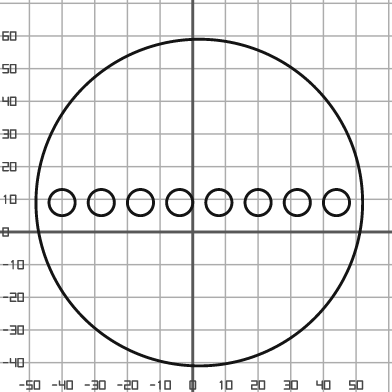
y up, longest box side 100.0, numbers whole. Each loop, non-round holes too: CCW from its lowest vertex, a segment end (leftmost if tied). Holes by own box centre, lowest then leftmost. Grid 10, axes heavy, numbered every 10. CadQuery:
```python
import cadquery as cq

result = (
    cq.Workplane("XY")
    .moveTo(2.0, 9.0)
    .circle(50.0)
    .moveTo(-40.0, 9.0)
    .circle(4.0)
    .moveTo(-28.0, 9.0)
    .circle(4.0)
    .moveTo(-16.0, 9.0)
    .circle(4.0)
    .moveTo(-4.0, 9.0)
    .circle(4.0)
    .moveTo(8.0, 9.0)
    .circle(4.0)
    .moveTo(20.0, 9.0)
    .circle(4.0)
    .moveTo(32.0, 9.0)
    .circle(4.0)
    .moveTo(44.0, 9.0)
    .circle(4.0)
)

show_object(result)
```